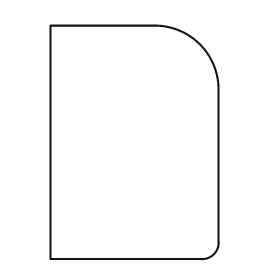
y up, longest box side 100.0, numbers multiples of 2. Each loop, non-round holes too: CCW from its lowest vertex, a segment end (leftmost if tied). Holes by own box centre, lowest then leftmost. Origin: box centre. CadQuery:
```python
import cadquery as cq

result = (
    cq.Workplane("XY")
    .moveTo(-36.0, -50.0)
    .lineTo(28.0, -50.0)
    .threePointArc((34.0, -48.0), (36.0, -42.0))
    .lineTo(36.0, 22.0)
    .threePointArc((28.0, 42.0), (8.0, 50.0))
    .lineTo(-36.0, 50.0)
    .close()
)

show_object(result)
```